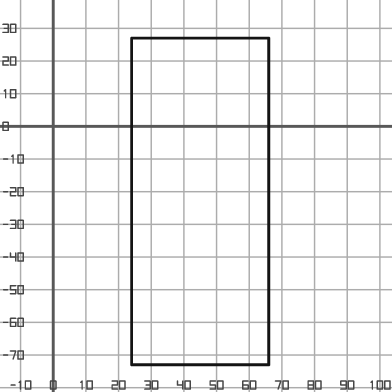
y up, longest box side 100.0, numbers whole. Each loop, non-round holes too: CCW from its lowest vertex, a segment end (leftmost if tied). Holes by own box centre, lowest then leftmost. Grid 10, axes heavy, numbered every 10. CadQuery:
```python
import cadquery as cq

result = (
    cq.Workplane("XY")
    .moveTo(24.0, -73.0)
    .lineTo(66.0, -73.0)
    .lineTo(66.0, 27.0)
    .lineTo(24.0, 27.0)
    .close()
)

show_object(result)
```